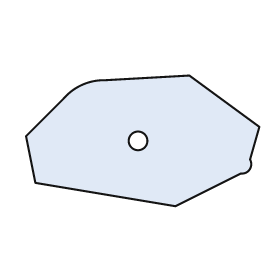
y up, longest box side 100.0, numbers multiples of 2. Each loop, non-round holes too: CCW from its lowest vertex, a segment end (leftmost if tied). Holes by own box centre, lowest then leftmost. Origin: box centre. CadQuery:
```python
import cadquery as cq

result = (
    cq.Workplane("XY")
    .moveTo(14.0, -28.0)
    .lineTo(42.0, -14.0)
    .threePointArc((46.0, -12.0), (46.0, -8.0))
    .lineTo(50.0, 6.0)
    .lineTo(20.0, 28.0)
    .lineTo(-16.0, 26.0)
    .threePointArc((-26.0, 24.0), (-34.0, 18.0))
    .lineTo(-50.0, 2.0)
    .lineTo(-46.0, -18.0)
    .close()
    .moveTo(-2.0, 0.0)
    .circle(4.0)
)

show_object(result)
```